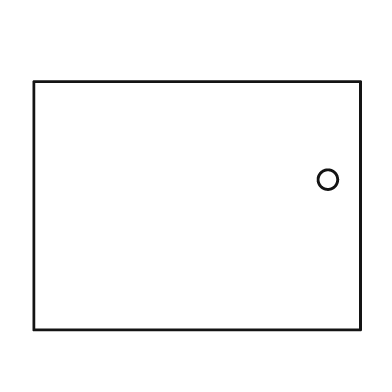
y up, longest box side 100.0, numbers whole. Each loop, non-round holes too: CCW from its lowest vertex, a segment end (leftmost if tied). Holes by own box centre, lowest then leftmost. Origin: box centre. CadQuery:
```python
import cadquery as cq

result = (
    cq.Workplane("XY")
    .moveTo(-50.0, -38.0)
    .lineTo(50.0, -38.0)
    .lineTo(50.0, 38.0)
    .lineTo(-50.0, 38.0)
    .close()
    .moveTo(40.0, 8.0)
    .circle(3.0)
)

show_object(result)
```